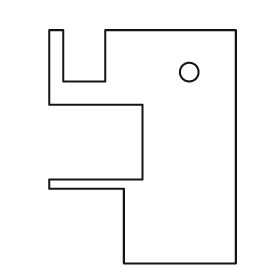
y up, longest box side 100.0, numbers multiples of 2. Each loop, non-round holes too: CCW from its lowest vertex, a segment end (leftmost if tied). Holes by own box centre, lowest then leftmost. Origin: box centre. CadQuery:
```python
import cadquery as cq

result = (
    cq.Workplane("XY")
    .moveTo(-8.0, -50.0)
    .lineTo(40.0, -50.0)
    .lineTo(40.0, 50.0)
    .lineTo(-16.0, 50.0)
    .lineTo(-16.0, 28.0)
    .lineTo(-34.0, 28.0)
    .lineTo(-34.0, 50.0)
    .lineTo(-40.0, 50.0)
    .lineTo(-40.0, 18.0)
    .lineTo(0.0, 18.0)
    .lineTo(0.0, -14.0)
    .lineTo(-40.0, -14.0)
    .lineTo(-40.0, -18.0)
    .lineTo(-8.0, -18.0)
    .close()
    .moveTo(20.0, 32.0)
    .circle(4.0)
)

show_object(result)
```